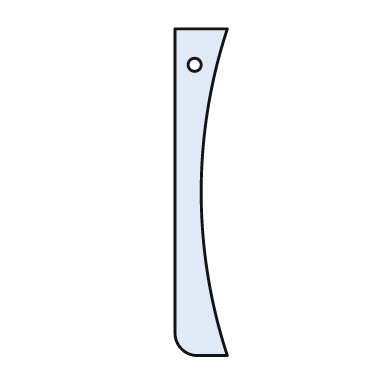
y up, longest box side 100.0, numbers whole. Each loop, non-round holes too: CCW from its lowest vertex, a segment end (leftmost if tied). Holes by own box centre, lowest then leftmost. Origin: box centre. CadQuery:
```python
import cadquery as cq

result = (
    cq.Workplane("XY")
    .moveTo(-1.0, -50.0)
    .lineTo(8.0, -50.0)
    .threePointArc((0.0, 0.0), (8.0, 50.0))
    .lineTo(-8.0, 50.0)
    .lineTo(-8.0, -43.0)
    .threePointArc((-6.0, -48.0), (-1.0, -50.0))
    .close()
    .moveTo(-2.0, 39.0)
    .circle(2.0)
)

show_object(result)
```